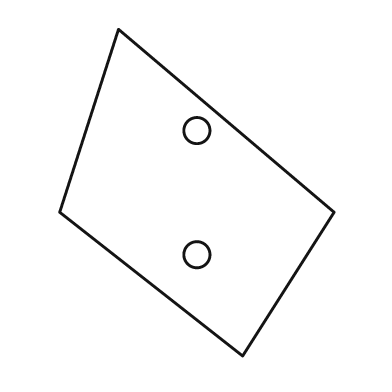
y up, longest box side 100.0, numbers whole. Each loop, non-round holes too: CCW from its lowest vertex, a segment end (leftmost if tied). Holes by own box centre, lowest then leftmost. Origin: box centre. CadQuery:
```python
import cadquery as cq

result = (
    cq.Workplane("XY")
    .moveTo(14.0, -50.0)
    .lineTo(42.0, -6.0)
    .lineTo(-24.0, 50.0)
    .lineTo(-42.0, -6.0)
    .close()
    .moveTo(0.0, -19.0)
    .circle(4.0)
    .moveTo(0.0, 19.0)
    .circle(4.0)
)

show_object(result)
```